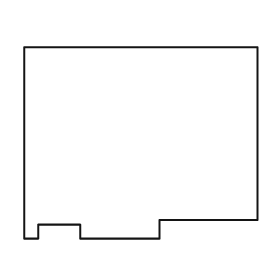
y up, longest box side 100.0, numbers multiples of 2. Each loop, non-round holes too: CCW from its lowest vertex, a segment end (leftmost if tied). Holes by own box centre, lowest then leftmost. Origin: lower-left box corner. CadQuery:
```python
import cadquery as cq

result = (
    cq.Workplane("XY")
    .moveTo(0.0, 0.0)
    .lineTo(6.0, 0.0)
    .lineTo(6.0, 6.0)
    .lineTo(24.0, 6.0)
    .lineTo(24.0, 0.0)
    .lineTo(58.0, 0.0)
    .lineTo(58.0, 8.0)
    .lineTo(100.0, 8.0)
    .lineTo(100.0, 82.0)
    .lineTo(0.0, 82.0)
    .close()
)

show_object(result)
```